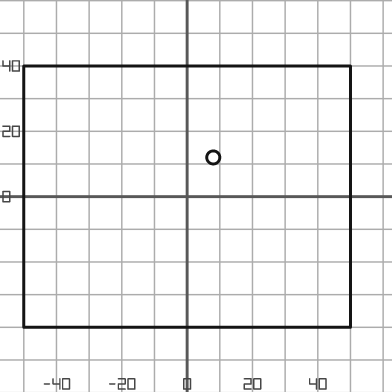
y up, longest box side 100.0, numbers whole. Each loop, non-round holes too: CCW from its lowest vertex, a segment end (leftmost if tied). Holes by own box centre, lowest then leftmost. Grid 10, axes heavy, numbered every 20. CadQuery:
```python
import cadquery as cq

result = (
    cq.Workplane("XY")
    .moveTo(-50.0, -40.0)
    .lineTo(50.0, -40.0)
    .lineTo(50.0, 40.0)
    .lineTo(-50.0, 40.0)
    .close()
    .moveTo(8.0, 12.0)
    .circle(2.0)
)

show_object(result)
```